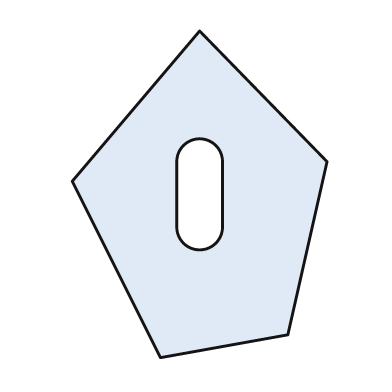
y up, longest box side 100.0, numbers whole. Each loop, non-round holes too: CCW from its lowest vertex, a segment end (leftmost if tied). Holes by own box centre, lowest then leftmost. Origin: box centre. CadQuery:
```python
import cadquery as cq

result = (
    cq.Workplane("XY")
    .moveTo(-12.0, -50.0)
    .lineTo(27.0, -43.0)
    .lineTo(39.0, 10.0)
    .lineTo(0.0, 50.0)
    .lineTo(-39.0, 4.0)
    .close()
    .moveTo(-7.0, -10.0)
    .threePointArc((0.0, -17.0), (7.0, -10.0))
    .lineTo(7.0, 10.0)
    .threePointArc((0.0, 17.0), (-7.0, 10.0))
    .close()
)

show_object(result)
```